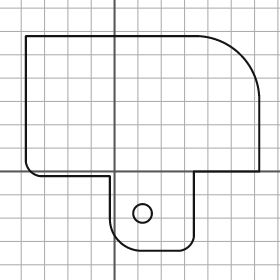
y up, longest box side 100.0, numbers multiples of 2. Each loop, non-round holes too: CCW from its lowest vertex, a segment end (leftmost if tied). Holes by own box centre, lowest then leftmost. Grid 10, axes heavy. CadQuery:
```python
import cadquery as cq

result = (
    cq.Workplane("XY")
    .moveTo(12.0, -34.0)
    .lineTo(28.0, -34.0)
    .threePointArc((32.0, -32.0), (34.0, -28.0))
    .lineTo(34.0, 0.0)
    .lineTo(62.0, 0.0)
    .lineTo(62.0, 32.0)
    .threePointArc((54.0, 50.0), (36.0, 58.0))
    .lineTo(-38.0, 58.0)
    .lineTo(-38.0, 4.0)
    .threePointArc((-36.0, 0.0), (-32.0, -2.0))
    .lineTo(-2.0, -2.0)
    .lineTo(-2.0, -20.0)
    .threePointArc((2.0, -30.0), (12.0, -34.0))
    .close()
    .moveTo(12.0, -18.0)
    .circle(4.0)
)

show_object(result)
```